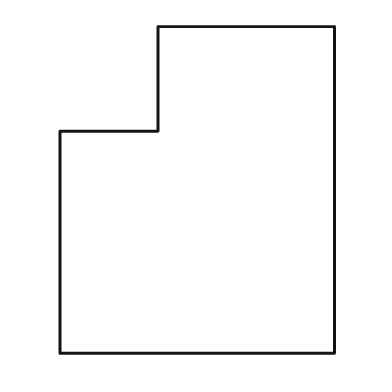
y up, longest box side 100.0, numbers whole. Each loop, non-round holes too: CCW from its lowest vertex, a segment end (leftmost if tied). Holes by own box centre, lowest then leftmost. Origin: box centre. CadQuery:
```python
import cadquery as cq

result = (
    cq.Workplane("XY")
    .moveTo(-42.0, -50.0)
    .lineTo(42.0, -50.0)
    .lineTo(42.0, 50.0)
    .lineTo(-12.0, 50.0)
    .lineTo(-12.0, 18.0)
    .lineTo(-42.0, 18.0)
    .close()
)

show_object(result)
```